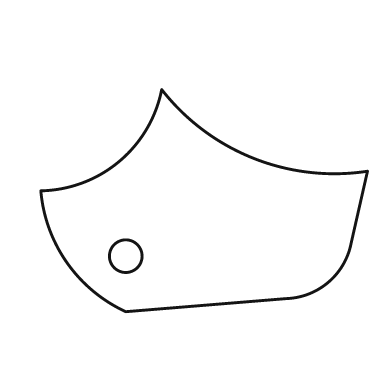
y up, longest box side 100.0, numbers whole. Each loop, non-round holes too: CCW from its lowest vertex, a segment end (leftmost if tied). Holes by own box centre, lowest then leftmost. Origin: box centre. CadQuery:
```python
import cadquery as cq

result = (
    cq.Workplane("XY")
    .moveTo(-24.0, -34.0)
    .lineTo(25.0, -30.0)
    .threePointArc((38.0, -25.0), (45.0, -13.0))
    .lineTo(50.0, 9.0)
    .threePointArc((15.0, 13.0), (-13.0, 34.0))
    .threePointArc((-26.0, 12.0), (-50.0, 3.0))
    .threePointArc((-42.0, -19.0), (-24.0, -34.0))
    .close()
    .moveTo(-24.0, -17.0)
    .circle(5.0)
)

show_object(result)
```